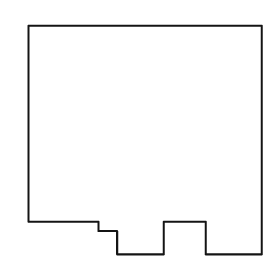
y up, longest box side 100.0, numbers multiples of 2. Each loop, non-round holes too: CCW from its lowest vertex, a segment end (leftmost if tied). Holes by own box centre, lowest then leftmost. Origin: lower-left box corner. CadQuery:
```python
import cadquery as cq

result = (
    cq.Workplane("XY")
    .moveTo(38.0, 0.0)
    .lineTo(58.0, 0.0)
    .lineTo(58.0, 14.0)
    .lineTo(76.0, 14.0)
    .lineTo(76.0, 0.0)
    .lineTo(100.0, 0.0)
    .lineTo(100.0, 98.0)
    .lineTo(0.0, 98.0)
    .lineTo(0.0, 14.0)
    .lineTo(30.0, 14.0)
    .lineTo(30.0, 10.0)
    .lineTo(38.0, 10.0)
    .close()
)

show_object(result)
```